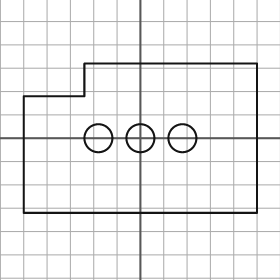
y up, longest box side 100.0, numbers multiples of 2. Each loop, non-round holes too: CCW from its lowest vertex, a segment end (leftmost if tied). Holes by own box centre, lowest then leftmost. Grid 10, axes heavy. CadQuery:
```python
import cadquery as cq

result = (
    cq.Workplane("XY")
    .moveTo(-50.0, -32.0)
    .lineTo(50.0, -32.0)
    .lineTo(50.0, 32.0)
    .lineTo(-24.0, 32.0)
    .lineTo(-24.0, 18.0)
    .lineTo(-50.0, 18.0)
    .close()
    .moveTo(-18.0, 0.0)
    .circle(6.0)
    .moveTo(0.0, 0.0)
    .circle(6.0)
    .moveTo(18.0, 0.0)
    .circle(6.0)
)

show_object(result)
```